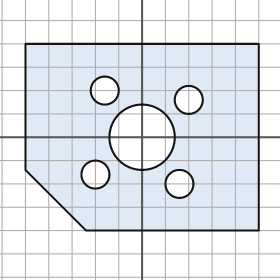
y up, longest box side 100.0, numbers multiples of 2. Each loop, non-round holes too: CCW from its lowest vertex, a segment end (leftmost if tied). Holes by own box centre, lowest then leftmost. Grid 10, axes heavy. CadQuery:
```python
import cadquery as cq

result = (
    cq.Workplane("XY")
    .moveTo(-24.0, -40.0)
    .lineTo(50.0, -40.0)
    .lineTo(50.0, 40.0)
    .lineTo(-50.0, 40.0)
    .lineTo(-50.0, -14.0)
    .close()
    .moveTo(16.0, -20.0)
    .circle(6.0)
    .moveTo(-20.0, -16.0)
    .circle(6.0)
    .moveTo(0.0, 0.0)
    .circle(14.0)
    .moveTo(20.0, 16.0)
    .circle(6.0)
    .moveTo(-16.0, 20.0)
    .circle(6.0)
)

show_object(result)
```